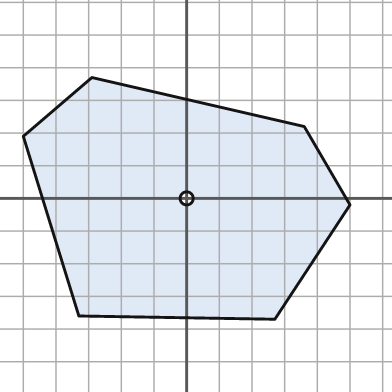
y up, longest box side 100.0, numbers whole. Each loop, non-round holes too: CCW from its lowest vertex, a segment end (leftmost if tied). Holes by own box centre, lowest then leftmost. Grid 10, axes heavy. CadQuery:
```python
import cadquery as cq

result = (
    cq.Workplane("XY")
    .moveTo(27.0, -37.0)
    .lineTo(50.0, -2.0)
    .lineTo(36.0, 22.0)
    .lineTo(-29.0, 37.0)
    .lineTo(-50.0, 19.0)
    .lineTo(-33.0, -36.0)
    .close()
    .moveTo(0.0, 0.0)
    .circle(2.0)
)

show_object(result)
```